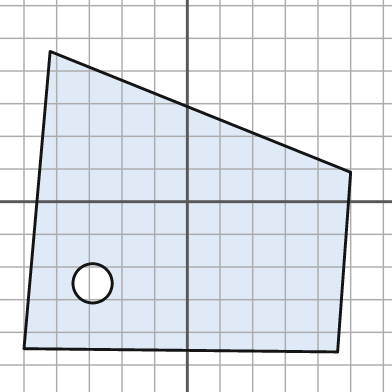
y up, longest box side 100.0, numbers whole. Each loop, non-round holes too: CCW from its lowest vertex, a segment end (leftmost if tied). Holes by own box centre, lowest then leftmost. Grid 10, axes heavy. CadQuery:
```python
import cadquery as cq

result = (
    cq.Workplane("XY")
    .moveTo(46.0, -46.0)
    .lineTo(50.0, 9.0)
    .lineTo(-42.0, 46.0)
    .lineTo(-50.0, -45.0)
    .close()
    .moveTo(-29.0, -25.0)
    .circle(6.0)
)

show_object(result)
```